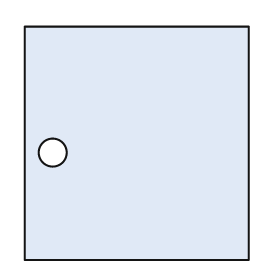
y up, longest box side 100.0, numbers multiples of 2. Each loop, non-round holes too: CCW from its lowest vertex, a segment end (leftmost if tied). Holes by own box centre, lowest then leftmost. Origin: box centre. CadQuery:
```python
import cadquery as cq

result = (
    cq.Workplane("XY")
    .moveTo(-48.0, -50.0)
    .lineTo(48.0, -50.0)
    .lineTo(48.0, 50.0)
    .lineTo(-48.0, 50.0)
    .close()
    .moveTo(-36.0, -4.0)
    .circle(6.0)
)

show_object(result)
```